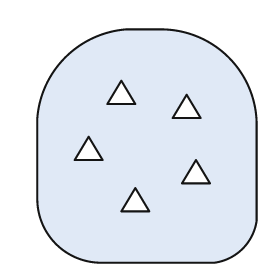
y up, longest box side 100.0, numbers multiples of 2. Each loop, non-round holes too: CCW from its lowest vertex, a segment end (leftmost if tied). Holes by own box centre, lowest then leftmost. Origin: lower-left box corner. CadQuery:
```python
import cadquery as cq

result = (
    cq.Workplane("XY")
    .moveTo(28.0, 0.0)
    .lineTo(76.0, 0.0)
    .threePointArc((88.0, 6.0), (94.0, 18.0))
    .lineTo(94.0, 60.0)
    .threePointArc((82.0, 88.0), (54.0, 100.0))
    .lineTo(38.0, 100.0)
    .threePointArc((12.0, 88.0), (0.0, 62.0))
    .lineTo(0.0, 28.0)
    .threePointArc((8.0, 8.0), (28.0, 0.0))
    .close()
    .moveTo(36.0, 22.0)
    .lineTo(48.0, 22.0)
    .lineTo(42.0, 32.0)
    .close()
    .moveTo(62.0, 34.0)
    .lineTo(74.0, 34.0)
    .lineTo(68.0, 44.0)
    .close()
    .moveTo(16.0, 44.0)
    .lineTo(28.0, 44.0)
    .lineTo(22.0, 54.0)
    .close()
    .moveTo(58.0, 62.0)
    .lineTo(70.0, 62.0)
    .lineTo(64.0, 72.0)
    .close()
    .moveTo(30.0, 68.0)
    .lineTo(42.0, 68.0)
    .lineTo(36.0, 78.0)
    .close()
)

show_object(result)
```